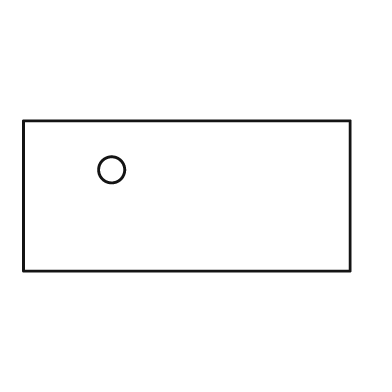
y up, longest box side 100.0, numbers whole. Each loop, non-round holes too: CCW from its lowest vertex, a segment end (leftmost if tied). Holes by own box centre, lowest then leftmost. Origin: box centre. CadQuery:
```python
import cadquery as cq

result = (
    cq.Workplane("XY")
    .moveTo(-50.0, -23.0)
    .lineTo(50.0, -23.0)
    .lineTo(50.0, 23.0)
    .lineTo(-50.0, 23.0)
    .close()
    .moveTo(-23.0, 8.0)
    .circle(4.0)
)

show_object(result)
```